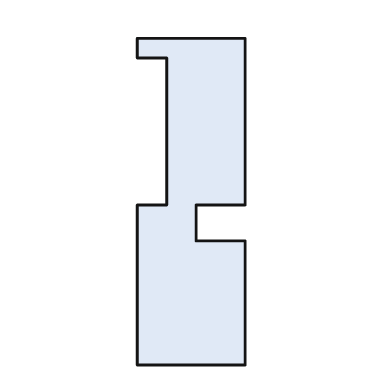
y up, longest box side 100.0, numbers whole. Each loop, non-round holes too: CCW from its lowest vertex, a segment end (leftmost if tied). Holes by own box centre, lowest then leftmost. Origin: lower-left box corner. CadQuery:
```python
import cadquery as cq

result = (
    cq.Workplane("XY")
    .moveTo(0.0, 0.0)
    .lineTo(33.0, 0.0)
    .lineTo(33.0, 38.0)
    .lineTo(18.0, 38.0)
    .lineTo(18.0, 49.0)
    .lineTo(33.0, 49.0)
    .lineTo(33.0, 100.0)
    .lineTo(0.0, 100.0)
    .lineTo(0.0, 94.0)
    .lineTo(9.0, 94.0)
    .lineTo(9.0, 49.0)
    .lineTo(0.0, 49.0)
    .close()
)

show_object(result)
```